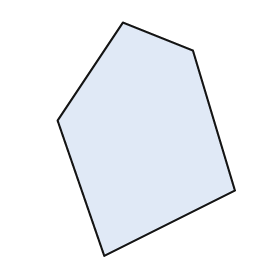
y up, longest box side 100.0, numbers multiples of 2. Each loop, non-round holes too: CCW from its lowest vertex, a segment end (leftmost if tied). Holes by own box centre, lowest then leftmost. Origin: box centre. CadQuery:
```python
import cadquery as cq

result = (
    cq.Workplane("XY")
    .moveTo(-18.0, -50.0)
    .lineTo(38.0, -22.0)
    .lineTo(20.0, 38.0)
    .lineTo(-10.0, 50.0)
    .lineTo(-38.0, 8.0)
    .close()
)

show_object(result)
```